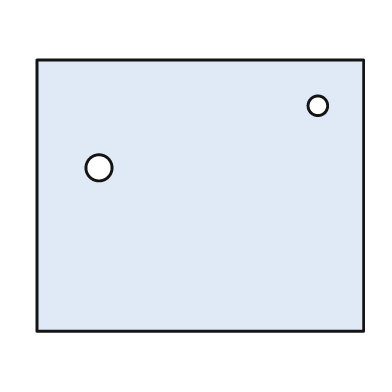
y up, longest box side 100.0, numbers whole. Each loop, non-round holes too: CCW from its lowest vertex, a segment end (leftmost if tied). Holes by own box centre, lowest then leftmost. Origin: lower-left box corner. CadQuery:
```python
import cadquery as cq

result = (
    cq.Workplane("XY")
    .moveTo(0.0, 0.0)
    .lineTo(100.0, 0.0)
    .lineTo(100.0, 83.0)
    .lineTo(0.0, 83.0)
    .close()
    .moveTo(19.0, 50.0)
    .circle(4.0)
    .moveTo(86.0, 69.0)
    .circle(3.0)
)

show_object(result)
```